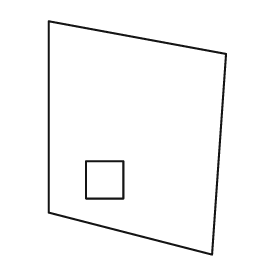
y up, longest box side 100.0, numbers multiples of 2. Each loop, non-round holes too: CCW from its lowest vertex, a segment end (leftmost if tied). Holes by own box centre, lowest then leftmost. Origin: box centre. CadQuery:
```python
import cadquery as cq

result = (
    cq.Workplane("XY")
    .moveTo(32.0, -50.0)
    .lineTo(38.0, 36.0)
    .lineTo(-38.0, 50.0)
    .lineTo(-38.0, -32.0)
    .close()
    .moveTo(-22.0, -26.0)
    .lineTo(-6.0, -26.0)
    .lineTo(-6.0, -10.0)
    .lineTo(-22.0, -10.0)
    .close()
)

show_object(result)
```